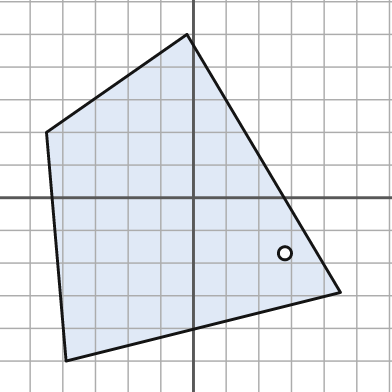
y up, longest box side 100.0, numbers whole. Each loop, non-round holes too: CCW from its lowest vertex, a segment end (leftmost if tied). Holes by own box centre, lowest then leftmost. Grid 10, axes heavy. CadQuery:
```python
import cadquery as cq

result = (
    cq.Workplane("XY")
    .moveTo(-39.0, -50.0)
    .lineTo(45.0, -29.0)
    .lineTo(-2.0, 50.0)
    .lineTo(-45.0, 20.0)
    .close()
    .moveTo(28.0, -17.0)
    .circle(2.0)
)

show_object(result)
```